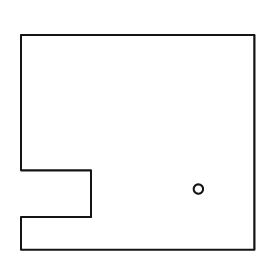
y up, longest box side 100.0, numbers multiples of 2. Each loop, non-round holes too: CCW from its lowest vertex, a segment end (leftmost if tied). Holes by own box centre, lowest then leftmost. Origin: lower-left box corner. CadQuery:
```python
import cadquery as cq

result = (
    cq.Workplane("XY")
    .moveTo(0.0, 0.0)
    .lineTo(100.0, 0.0)
    .lineTo(100.0, 92.0)
    .lineTo(0.0, 92.0)
    .lineTo(0.0, 34.0)
    .lineTo(30.0, 34.0)
    .lineTo(30.0, 14.0)
    .lineTo(0.0, 14.0)
    .close()
    .moveTo(76.0, 26.0)
    .circle(2.0)
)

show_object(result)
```